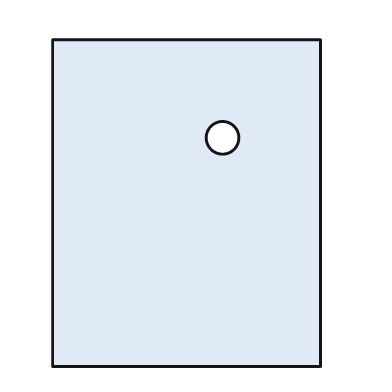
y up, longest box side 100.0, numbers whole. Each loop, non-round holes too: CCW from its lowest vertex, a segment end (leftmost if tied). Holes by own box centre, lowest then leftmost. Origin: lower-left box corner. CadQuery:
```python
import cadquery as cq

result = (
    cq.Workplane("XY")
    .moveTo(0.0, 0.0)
    .lineTo(82.0, 0.0)
    .lineTo(82.0, 100.0)
    .lineTo(0.0, 100.0)
    .close()
    .moveTo(52.0, 70.0)
    .circle(5.0)
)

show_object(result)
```